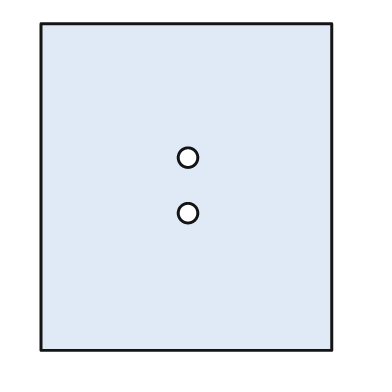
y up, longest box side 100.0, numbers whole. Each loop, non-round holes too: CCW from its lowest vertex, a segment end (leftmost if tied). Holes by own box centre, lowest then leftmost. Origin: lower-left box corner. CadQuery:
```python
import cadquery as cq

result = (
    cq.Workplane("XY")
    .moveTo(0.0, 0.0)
    .lineTo(89.0, 0.0)
    .lineTo(89.0, 100.0)
    .lineTo(0.0, 100.0)
    .close()
    .moveTo(45.0, 42.0)
    .circle(3.0)
    .moveTo(45.0, 59.0)
    .circle(3.0)
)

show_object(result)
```